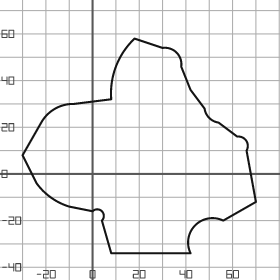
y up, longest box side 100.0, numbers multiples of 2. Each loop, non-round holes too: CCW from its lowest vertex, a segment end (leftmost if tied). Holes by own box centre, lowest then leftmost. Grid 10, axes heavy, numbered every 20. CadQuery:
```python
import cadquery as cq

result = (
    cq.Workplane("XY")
    .moveTo(8.0, -34.0)
    .lineTo(42.0, -34.0)
    .threePointArc((44.0, -22.0), (56.0, -20.0))
    .lineTo(70.0, -12.0)
    .lineTo(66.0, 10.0)
    .threePointArc((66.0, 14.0), (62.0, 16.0))
    .lineTo(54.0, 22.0)
    .threePointArc((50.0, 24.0), (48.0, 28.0))
    .lineTo(42.0, 36.0)
    .lineTo(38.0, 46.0)
    .threePointArc((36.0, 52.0), (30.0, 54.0))
    .lineTo(18.0, 58.0)
    .threePointArc((10.0, 46.0), (8.0, 32.0))
    .lineTo(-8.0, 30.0)
    .threePointArc((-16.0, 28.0), (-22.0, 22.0))
    .lineTo(-30.0, 8.0)
    .lineTo(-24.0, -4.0)
    .threePointArc((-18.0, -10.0), (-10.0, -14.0))
    .lineTo(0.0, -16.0)
    .threePointArc((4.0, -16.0), (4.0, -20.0))
    .close()
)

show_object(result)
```